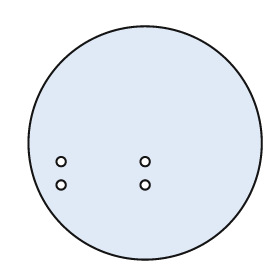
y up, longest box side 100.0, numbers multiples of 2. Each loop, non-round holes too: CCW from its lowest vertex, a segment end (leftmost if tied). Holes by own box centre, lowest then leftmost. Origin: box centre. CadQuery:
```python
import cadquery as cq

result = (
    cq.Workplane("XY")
    .moveTo(0.0, 0.0)
    .circle(50.0)
    .moveTo(-36.0, -18.0)
    .circle(2.0)
    .moveTo(0.0, -18.0)
    .circle(2.0)
    .moveTo(-36.0, -8.0)
    .circle(2.0)
    .moveTo(0.0, -8.0)
    .circle(2.0)
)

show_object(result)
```